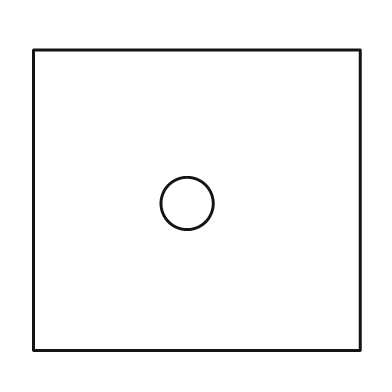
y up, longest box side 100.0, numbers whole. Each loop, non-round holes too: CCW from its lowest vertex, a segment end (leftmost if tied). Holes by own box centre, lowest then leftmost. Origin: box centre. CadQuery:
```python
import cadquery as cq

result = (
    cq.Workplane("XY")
    .moveTo(-50.0, -46.0)
    .lineTo(50.0, -46.0)
    .lineTo(50.0, 46.0)
    .lineTo(-50.0, 46.0)
    .close()
    .moveTo(-3.0, -1.0)
    .circle(8.0)
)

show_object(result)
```